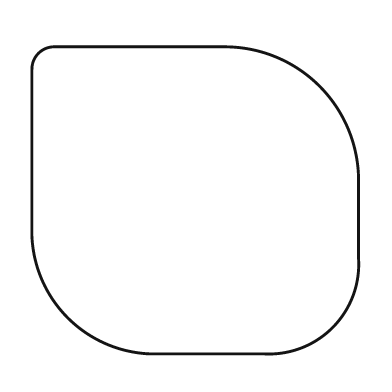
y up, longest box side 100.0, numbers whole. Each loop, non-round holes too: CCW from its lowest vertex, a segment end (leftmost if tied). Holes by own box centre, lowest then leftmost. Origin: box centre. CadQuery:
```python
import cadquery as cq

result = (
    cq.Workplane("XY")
    .moveTo(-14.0, -47.0)
    .lineTo(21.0, -47.0)
    .threePointArc((42.0, -39.0), (50.0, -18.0))
    .lineTo(50.0, 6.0)
    .threePointArc((38.0, 35.0), (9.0, 47.0))
    .lineTo(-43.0, 47.0)
    .threePointArc((-48.0, 45.0), (-50.0, 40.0))
    .lineTo(-50.0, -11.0)
    .threePointArc((-39.0, -36.0), (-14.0, -47.0))
    .close()
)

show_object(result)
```